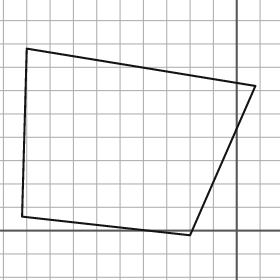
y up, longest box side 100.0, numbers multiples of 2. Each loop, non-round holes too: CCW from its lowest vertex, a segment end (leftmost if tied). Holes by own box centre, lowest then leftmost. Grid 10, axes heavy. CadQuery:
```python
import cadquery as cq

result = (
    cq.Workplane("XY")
    .moveTo(-20.0, -2.0)
    .lineTo(8.0, 62.0)
    .lineTo(-90.0, 78.0)
    .lineTo(-92.0, 6.0)
    .close()
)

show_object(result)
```